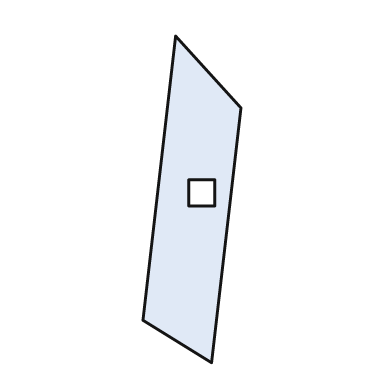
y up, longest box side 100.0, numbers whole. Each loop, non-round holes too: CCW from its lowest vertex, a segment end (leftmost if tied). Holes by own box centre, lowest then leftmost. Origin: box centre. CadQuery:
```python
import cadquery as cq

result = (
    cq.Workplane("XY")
    .moveTo(6.0, -50.0)
    .lineTo(15.0, 28.0)
    .lineTo(-5.0, 50.0)
    .lineTo(-15.0, -37.0)
    .close()
    .moveTo(-1.0, -2.0)
    .lineTo(7.0, -2.0)
    .lineTo(7.0, 6.0)
    .lineTo(-1.0, 6.0)
    .close()
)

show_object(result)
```